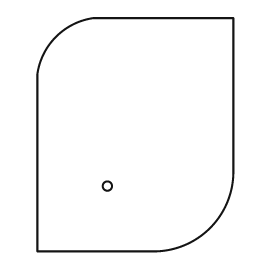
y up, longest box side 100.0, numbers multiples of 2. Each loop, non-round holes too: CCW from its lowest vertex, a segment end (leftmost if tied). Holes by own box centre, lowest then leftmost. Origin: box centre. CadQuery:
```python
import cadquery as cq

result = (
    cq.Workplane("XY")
    .moveTo(-42.0, -50.0)
    .lineTo(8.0, -50.0)
    .threePointArc((32.0, -40.0), (42.0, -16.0))
    .lineTo(42.0, 50.0)
    .lineTo(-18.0, 50.0)
    .threePointArc((-34.0, 42.0), (-42.0, 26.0))
    .close()
    .moveTo(-12.0, -22.0)
    .circle(2.0)
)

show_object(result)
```